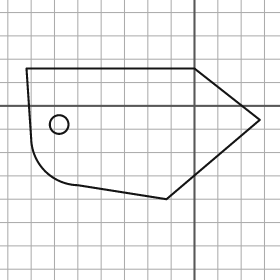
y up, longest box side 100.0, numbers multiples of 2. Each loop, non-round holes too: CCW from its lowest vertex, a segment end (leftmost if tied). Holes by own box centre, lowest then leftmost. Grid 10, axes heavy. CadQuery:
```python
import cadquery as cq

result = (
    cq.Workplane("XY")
    .moveTo(-12.0, -40.0)
    .lineTo(28.0, -6.0)
    .lineTo(0.0, 16.0)
    .lineTo(-72.0, 16.0)
    .lineTo(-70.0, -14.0)
    .threePointArc((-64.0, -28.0), (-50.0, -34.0))
    .close()
    .moveTo(-58.0, -8.0)
    .circle(4.0)
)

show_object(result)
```